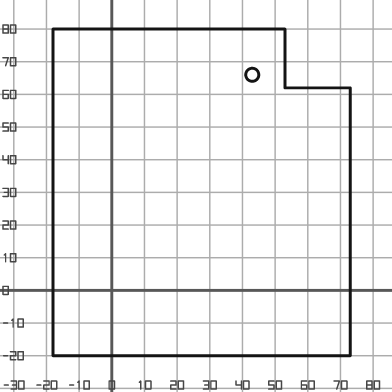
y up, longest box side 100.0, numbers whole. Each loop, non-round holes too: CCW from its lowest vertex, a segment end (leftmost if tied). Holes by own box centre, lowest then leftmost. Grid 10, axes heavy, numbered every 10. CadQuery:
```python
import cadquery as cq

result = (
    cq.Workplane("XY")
    .moveTo(-18.0, -20.0)
    .lineTo(73.0, -20.0)
    .lineTo(73.0, 62.0)
    .lineTo(53.0, 62.0)
    .lineTo(53.0, 80.0)
    .lineTo(-18.0, 80.0)
    .close()
    .moveTo(43.0, 66.0)
    .circle(2.0)
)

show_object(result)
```